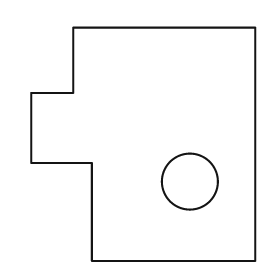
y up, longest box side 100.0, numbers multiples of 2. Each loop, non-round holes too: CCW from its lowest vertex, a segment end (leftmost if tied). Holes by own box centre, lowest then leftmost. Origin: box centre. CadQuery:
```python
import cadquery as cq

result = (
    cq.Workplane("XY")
    .moveTo(-22.0, -50.0)
    .lineTo(48.0, -50.0)
    .lineTo(48.0, 50.0)
    .lineTo(-30.0, 50.0)
    .lineTo(-30.0, 22.0)
    .lineTo(-48.0, 22.0)
    .lineTo(-48.0, -8.0)
    .lineTo(-22.0, -8.0)
    .close()
    .moveTo(20.0, -16.0)
    .circle(12.0)
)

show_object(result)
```